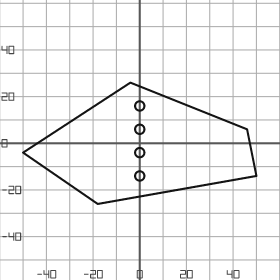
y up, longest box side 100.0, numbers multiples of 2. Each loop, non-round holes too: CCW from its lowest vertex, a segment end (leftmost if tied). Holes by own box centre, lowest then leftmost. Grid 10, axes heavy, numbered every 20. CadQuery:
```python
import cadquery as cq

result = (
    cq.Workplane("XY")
    .moveTo(-18.0, -26.0)
    .lineTo(50.0, -14.0)
    .lineTo(46.0, 6.0)
    .lineTo(-4.0, 26.0)
    .lineTo(-50.0, -4.0)
    .close()
    .moveTo(0.0, -14.0)
    .circle(2.0)
    .moveTo(0.0, -4.0)
    .circle(2.0)
    .moveTo(0.0, 6.0)
    .circle(2.0)
    .moveTo(0.0, 16.0)
    .circle(2.0)
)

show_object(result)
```